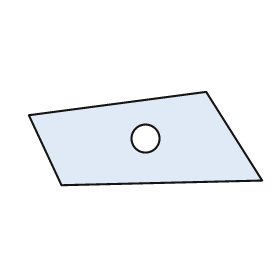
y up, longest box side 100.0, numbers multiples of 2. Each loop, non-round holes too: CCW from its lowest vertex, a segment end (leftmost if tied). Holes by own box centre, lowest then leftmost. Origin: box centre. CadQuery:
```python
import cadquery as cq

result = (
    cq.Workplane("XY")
    .moveTo(-36.0, -20.0)
    .lineTo(50.0, -18.0)
    .lineTo(26.0, 20.0)
    .lineTo(-50.0, 10.0)
    .close()
    .moveTo(0.0, 0.0)
    .circle(6.0)
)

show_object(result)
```